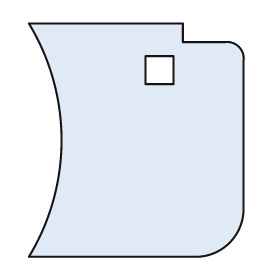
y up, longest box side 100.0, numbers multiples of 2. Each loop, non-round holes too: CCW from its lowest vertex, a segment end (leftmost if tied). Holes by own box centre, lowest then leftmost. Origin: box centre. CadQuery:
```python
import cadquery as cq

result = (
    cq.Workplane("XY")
    .moveTo(-46.0, -50.0)
    .lineTo(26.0, -50.0)
    .threePointArc((40.0, -44.0), (46.0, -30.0))
    .lineTo(46.0, 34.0)
    .threePointArc((44.0, 40.0), (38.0, 42.0))
    .lineTo(20.0, 42.0)
    .lineTo(20.0, 50.0)
    .lineTo(-46.0, 50.0)
    .threePointArc((-32.0, 0.0), (-46.0, -50.0))
    .close()
    .moveTo(4.0, 24.0)
    .lineTo(16.0, 24.0)
    .lineTo(16.0, 36.0)
    .lineTo(4.0, 36.0)
    .close()
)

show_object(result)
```